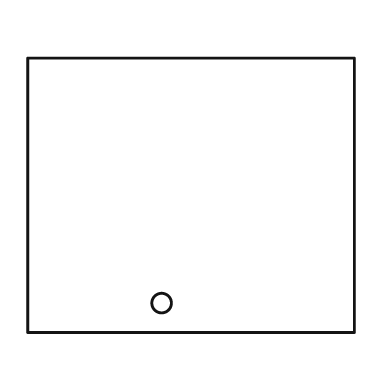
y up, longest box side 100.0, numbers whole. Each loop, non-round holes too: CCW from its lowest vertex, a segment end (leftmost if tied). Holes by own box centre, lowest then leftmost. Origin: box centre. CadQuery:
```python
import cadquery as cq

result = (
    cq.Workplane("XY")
    .moveTo(-50.0, -42.0)
    .lineTo(50.0, -42.0)
    .lineTo(50.0, 42.0)
    .lineTo(-50.0, 42.0)
    .close()
    .moveTo(-9.0, -33.0)
    .circle(3.0)
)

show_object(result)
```